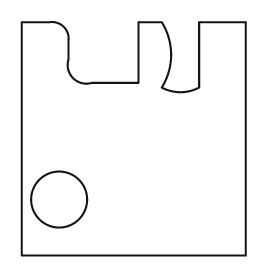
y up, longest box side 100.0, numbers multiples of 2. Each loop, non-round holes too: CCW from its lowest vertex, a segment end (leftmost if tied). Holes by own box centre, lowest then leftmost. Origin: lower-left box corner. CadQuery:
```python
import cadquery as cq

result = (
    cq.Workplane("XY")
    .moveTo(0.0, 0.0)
    .lineTo(96.0, 0.0)
    .lineTo(96.0, 100.0)
    .lineTo(76.0, 100.0)
    .lineTo(76.0, 72.0)
    .threePointArc((68.0, 70.0), (60.0, 72.0))
    .threePointArc((64.0, 86.0), (60.0, 100.0))
    .lineTo(50.0, 100.0)
    .lineTo(50.0, 74.0)
    .lineTo(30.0, 74.0)
    .threePointArc((22.0, 76.0), (20.0, 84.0))
    .lineTo(20.0, 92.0)
    .threePointArc((18.0, 98.0), (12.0, 100.0))
    .lineTo(0.0, 100.0)
    .close()
    .moveTo(16.0, 24.0)
    .circle(12.0)
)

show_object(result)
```